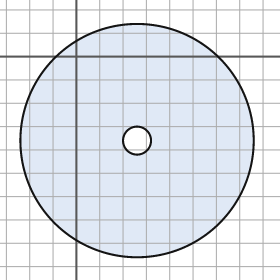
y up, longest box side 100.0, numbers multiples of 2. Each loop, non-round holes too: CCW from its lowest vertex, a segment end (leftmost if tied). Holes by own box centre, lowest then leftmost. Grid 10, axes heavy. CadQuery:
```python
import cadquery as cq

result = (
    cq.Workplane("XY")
    .moveTo(26.0, -36.0)
    .circle(50.0)
    .moveTo(26.0, -36.0)
    .circle(6.0)
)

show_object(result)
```